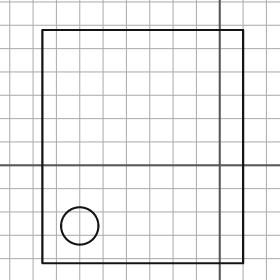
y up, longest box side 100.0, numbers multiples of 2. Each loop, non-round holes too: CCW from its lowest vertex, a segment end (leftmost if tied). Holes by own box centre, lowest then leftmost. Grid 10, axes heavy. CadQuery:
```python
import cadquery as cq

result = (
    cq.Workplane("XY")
    .moveTo(-76.0, -42.0)
    .lineTo(10.0, -42.0)
    .lineTo(10.0, 58.0)
    .lineTo(-76.0, 58.0)
    .close()
    .moveTo(-60.0, -26.0)
    .circle(8.0)
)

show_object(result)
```